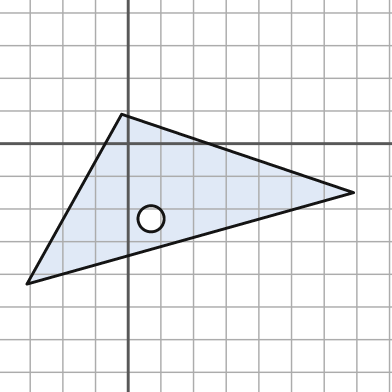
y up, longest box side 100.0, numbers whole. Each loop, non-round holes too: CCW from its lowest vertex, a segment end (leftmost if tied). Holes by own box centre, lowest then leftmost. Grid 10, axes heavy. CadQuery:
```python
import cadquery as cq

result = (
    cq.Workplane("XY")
    .moveTo(-31.0, -43.0)
    .lineTo(69.0, -15.0)
    .lineTo(-2.0, 9.0)
    .close()
    .moveTo(7.0, -23.0)
    .circle(4.0)
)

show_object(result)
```